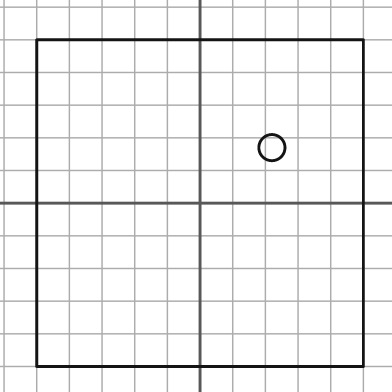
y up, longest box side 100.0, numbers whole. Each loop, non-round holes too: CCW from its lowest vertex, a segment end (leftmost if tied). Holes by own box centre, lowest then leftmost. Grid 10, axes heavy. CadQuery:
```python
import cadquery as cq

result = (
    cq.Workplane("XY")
    .moveTo(-50.0, -50.0)
    .lineTo(50.0, -50.0)
    .lineTo(50.0, 50.0)
    .lineTo(-50.0, 50.0)
    .close()
    .moveTo(22.0, 17.0)
    .circle(4.0)
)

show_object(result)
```